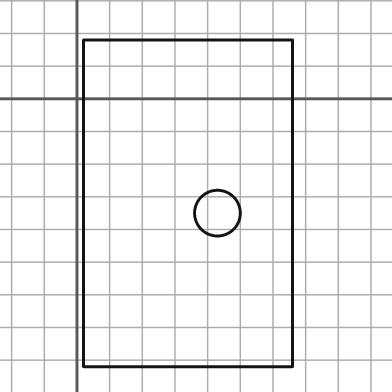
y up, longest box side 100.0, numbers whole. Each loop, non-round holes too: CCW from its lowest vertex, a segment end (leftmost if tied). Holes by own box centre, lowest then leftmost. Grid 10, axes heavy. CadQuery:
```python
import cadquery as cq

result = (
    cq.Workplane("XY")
    .moveTo(2.0, -82.0)
    .lineTo(66.0, -82.0)
    .lineTo(66.0, 18.0)
    .lineTo(2.0, 18.0)
    .close()
    .moveTo(43.0, -35.0)
    .circle(7.0)
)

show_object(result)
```